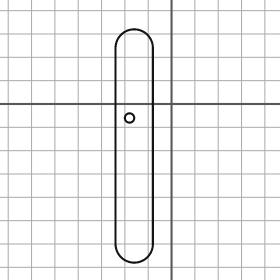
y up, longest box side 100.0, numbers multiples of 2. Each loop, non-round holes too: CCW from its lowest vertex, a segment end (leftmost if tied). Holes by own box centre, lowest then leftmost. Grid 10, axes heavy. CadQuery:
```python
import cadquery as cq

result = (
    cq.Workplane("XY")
    .moveTo(-24.0, -60.0)
    .threePointArc((-16.0, -68.0), (-8.0, -60.0))
    .lineTo(-8.0, 24.0)
    .threePointArc((-16.0, 32.0), (-24.0, 24.0))
    .close()
    .moveTo(-18.0, -6.0)
    .circle(2.0)
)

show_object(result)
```